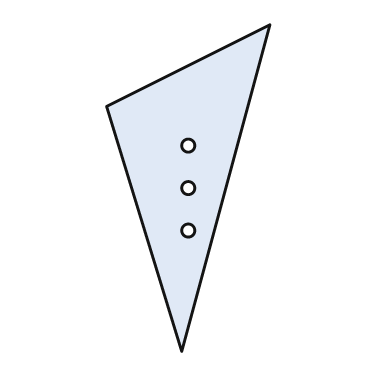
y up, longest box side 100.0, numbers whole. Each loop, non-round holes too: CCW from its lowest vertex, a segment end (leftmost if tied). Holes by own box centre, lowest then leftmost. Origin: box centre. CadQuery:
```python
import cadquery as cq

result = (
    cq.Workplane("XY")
    .moveTo(-2.0, -50.0)
    .lineTo(25.0, 50.0)
    .lineTo(-25.0, 25.0)
    .close()
    .moveTo(0.0, -13.0)
    .circle(2.0)
    .moveTo(0.0, 0.0)
    .circle(2.0)
    .moveTo(0.0, 13.0)
    .circle(2.0)
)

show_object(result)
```